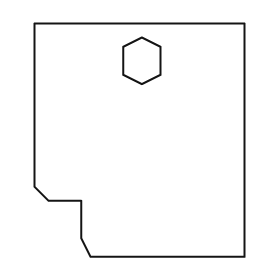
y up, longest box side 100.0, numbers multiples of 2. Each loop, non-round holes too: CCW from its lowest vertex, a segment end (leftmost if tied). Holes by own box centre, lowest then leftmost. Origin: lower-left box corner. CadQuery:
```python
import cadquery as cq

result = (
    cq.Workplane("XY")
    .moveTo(24.0, 0.0)
    .lineTo(90.0, 0.0)
    .lineTo(90.0, 100.0)
    .lineTo(0.0, 100.0)
    .lineTo(0.0, 30.0)
    .lineTo(6.0, 24.0)
    .lineTo(20.0, 24.0)
    .lineTo(20.0, 8.0)
    .close()
    .moveTo(46.0, 74.0)
    .lineTo(54.0, 78.0)
    .lineTo(54.0, 90.0)
    .lineTo(46.0, 94.0)
    .lineTo(38.0, 90.0)
    .lineTo(38.0, 78.0)
    .close()
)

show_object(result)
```